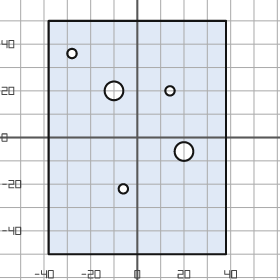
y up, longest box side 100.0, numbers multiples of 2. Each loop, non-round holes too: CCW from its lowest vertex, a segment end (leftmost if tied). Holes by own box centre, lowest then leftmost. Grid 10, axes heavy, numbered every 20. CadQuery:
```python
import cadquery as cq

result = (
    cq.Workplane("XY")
    .moveTo(-38.0, -50.0)
    .lineTo(38.0, -50.0)
    .lineTo(38.0, 50.0)
    .lineTo(-38.0, 50.0)
    .close()
    .moveTo(-6.0, -22.0)
    .circle(2.0)
    .moveTo(20.0, -6.0)
    .circle(4.0)
    .moveTo(-10.0, 20.0)
    .circle(4.0)
    .moveTo(14.0, 20.0)
    .circle(2.0)
    .moveTo(-28.0, 36.0)
    .circle(2.0)
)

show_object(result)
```